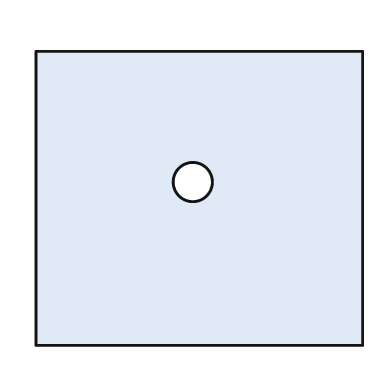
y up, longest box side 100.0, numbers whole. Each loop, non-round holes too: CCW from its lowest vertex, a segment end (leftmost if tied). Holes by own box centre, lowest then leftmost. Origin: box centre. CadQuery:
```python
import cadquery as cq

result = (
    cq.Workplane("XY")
    .moveTo(-50.0, -45.0)
    .lineTo(50.0, -45.0)
    .lineTo(50.0, 45.0)
    .lineTo(-50.0, 45.0)
    .close()
    .moveTo(-2.0, 5.0)
    .circle(6.0)
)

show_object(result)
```